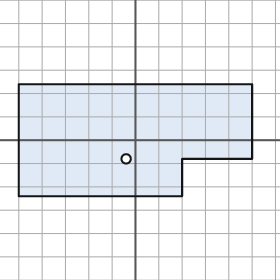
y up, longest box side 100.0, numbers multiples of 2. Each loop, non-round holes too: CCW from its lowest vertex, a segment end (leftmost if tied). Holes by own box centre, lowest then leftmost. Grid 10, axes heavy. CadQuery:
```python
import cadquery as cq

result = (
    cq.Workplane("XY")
    .moveTo(-50.0, -24.0)
    .lineTo(20.0, -24.0)
    .lineTo(20.0, -8.0)
    .lineTo(50.0, -8.0)
    .lineTo(50.0, 24.0)
    .lineTo(-50.0, 24.0)
    .close()
    .moveTo(-4.0, -8.0)
    .circle(2.0)
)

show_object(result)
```